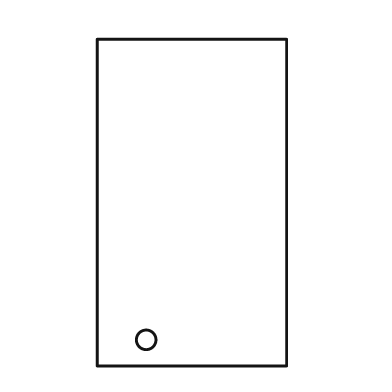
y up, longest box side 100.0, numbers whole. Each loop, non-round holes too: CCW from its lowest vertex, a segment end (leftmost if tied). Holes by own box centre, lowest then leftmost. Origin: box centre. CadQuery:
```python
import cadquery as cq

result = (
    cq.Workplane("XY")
    .moveTo(-29.0, -50.0)
    .lineTo(29.0, -50.0)
    .lineTo(29.0, 50.0)
    .lineTo(-29.0, 50.0)
    .close()
    .moveTo(-14.0, -42.0)
    .circle(3.0)
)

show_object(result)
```